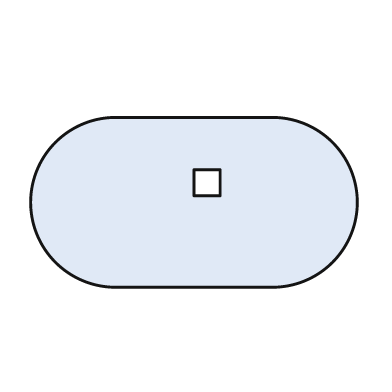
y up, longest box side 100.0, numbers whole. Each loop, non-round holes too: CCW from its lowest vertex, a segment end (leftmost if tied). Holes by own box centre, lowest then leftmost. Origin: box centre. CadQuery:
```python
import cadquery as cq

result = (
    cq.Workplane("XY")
    .moveTo(-24.0, -26.0)
    .lineTo(24.0, -26.0)
    .threePointArc((50.0, 0.0), (24.0, 26.0))
    .lineTo(-24.0, 26.0)
    .threePointArc((-50.0, 0.0), (-24.0, -26.0))
    .close()
    .moveTo(0.0, 2.0)
    .lineTo(8.0, 2.0)
    .lineTo(8.0, 10.0)
    .lineTo(0.0, 10.0)
    .close()
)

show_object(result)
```